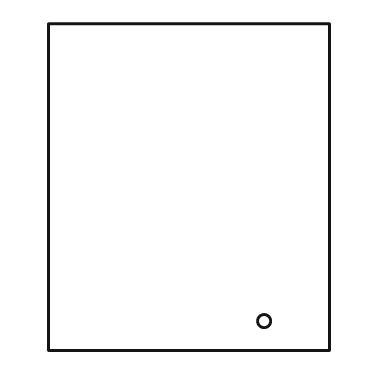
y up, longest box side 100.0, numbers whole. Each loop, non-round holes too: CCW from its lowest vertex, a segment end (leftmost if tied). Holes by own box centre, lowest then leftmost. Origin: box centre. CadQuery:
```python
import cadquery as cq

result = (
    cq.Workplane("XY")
    .moveTo(-43.0, -50.0)
    .lineTo(43.0, -50.0)
    .lineTo(43.0, 50.0)
    .lineTo(-43.0, 50.0)
    .close()
    .moveTo(23.0, -41.0)
    .circle(2.0)
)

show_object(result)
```